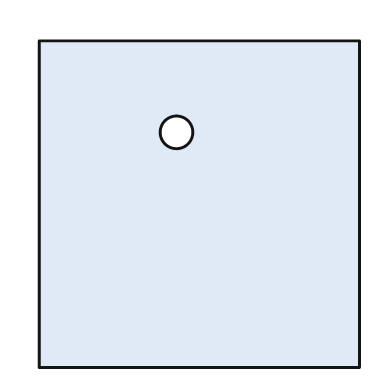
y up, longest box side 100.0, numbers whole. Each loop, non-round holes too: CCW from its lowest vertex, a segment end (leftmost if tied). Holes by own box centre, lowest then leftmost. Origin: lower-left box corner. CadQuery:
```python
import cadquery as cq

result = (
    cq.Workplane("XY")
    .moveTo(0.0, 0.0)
    .lineTo(98.0, 0.0)
    .lineTo(98.0, 100.0)
    .lineTo(0.0, 100.0)
    .close()
    .moveTo(42.0, 72.0)
    .circle(5.0)
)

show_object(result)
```